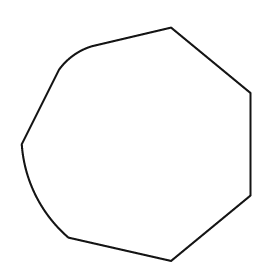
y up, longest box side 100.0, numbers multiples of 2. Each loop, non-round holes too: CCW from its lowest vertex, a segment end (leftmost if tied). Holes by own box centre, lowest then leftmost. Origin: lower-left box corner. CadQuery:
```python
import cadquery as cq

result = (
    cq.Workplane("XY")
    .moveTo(64.0, 0.0)
    .lineTo(98.0, 28.0)
    .lineTo(98.0, 72.0)
    .lineTo(64.0, 100.0)
    .lineTo(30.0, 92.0)
    .threePointArc((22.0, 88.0), (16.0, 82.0))
    .lineTo(0.0, 50.0)
    .threePointArc((6.0, 28.0), (20.0, 10.0))
    .close()
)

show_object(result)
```